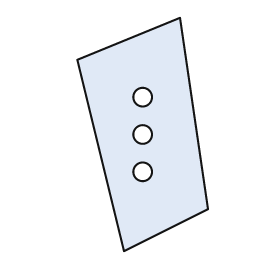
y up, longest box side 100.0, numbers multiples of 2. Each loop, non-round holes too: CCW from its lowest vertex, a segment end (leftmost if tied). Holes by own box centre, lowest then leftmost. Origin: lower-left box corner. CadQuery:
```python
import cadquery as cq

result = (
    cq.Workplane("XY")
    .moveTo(20.0, 0.0)
    .lineTo(56.0, 18.0)
    .lineTo(44.0, 100.0)
    .lineTo(0.0, 82.0)
    .close()
    .moveTo(28.0, 34.0)
    .circle(4.0)
    .moveTo(28.0, 50.0)
    .circle(4.0)
    .moveTo(28.0, 66.0)
    .circle(4.0)
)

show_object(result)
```